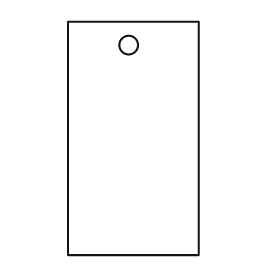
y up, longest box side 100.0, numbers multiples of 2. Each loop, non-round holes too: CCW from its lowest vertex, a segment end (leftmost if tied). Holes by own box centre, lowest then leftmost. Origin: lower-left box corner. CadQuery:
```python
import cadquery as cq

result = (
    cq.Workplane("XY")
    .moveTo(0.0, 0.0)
    .lineTo(56.0, 0.0)
    .lineTo(56.0, 100.0)
    .lineTo(0.0, 100.0)
    .close()
    .moveTo(26.0, 90.0)
    .circle(4.0)
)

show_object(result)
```